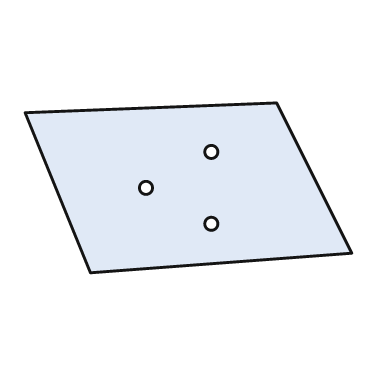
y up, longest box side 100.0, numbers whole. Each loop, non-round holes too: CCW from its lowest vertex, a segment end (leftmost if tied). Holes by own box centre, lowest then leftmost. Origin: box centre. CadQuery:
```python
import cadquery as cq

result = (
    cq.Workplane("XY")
    .moveTo(-30.0, -26.0)
    .lineTo(50.0, -20.0)
    .lineTo(27.0, 26.0)
    .lineTo(-50.0, 23.0)
    .close()
    .moveTo(7.0, -11.0)
    .circle(2.0)
    .moveTo(-13.0, 0.0)
    .circle(2.0)
    .moveTo(7.0, 11.0)
    .circle(2.0)
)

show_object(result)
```